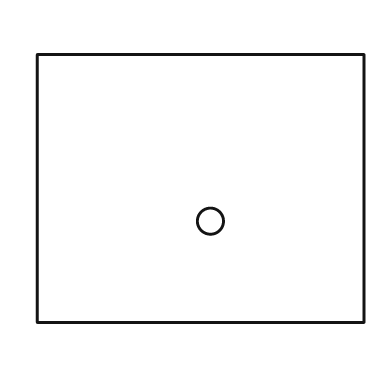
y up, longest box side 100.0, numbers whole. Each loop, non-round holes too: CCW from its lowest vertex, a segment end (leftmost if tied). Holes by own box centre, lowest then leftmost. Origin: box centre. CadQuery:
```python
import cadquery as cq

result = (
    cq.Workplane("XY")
    .moveTo(-50.0, -41.0)
    .lineTo(50.0, -41.0)
    .lineTo(50.0, 41.0)
    .lineTo(-50.0, 41.0)
    .close()
    .moveTo(3.0, -10.0)
    .circle(4.0)
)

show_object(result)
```